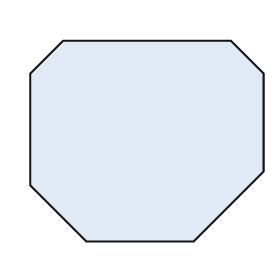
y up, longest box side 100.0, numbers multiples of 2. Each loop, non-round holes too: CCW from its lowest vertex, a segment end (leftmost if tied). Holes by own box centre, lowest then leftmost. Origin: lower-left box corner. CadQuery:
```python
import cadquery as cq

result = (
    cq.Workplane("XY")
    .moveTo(24.0, 0.0)
    .lineTo(70.0, 0.0)
    .lineTo(100.0, 30.0)
    .lineTo(100.0, 72.0)
    .lineTo(86.0, 86.0)
    .lineTo(14.0, 86.0)
    .lineTo(0.0, 72.0)
    .lineTo(0.0, 24.0)
    .close()
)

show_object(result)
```